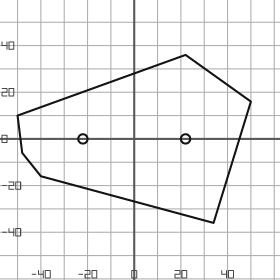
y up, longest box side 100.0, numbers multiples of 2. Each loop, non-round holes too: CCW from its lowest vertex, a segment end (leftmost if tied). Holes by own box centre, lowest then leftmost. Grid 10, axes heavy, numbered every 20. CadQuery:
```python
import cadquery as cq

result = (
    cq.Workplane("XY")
    .moveTo(34.0, -36.0)
    .lineTo(50.0, 16.0)
    .lineTo(22.0, 36.0)
    .lineTo(-50.0, 10.0)
    .lineTo(-48.0, -6.0)
    .lineTo(-40.0, -16.0)
    .close()
    .moveTo(-22.0, 0.0)
    .circle(2.0)
    .moveTo(22.0, 0.0)
    .circle(2.0)
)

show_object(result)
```